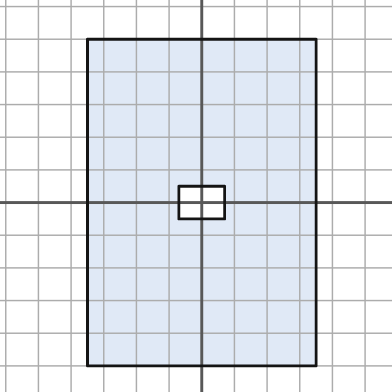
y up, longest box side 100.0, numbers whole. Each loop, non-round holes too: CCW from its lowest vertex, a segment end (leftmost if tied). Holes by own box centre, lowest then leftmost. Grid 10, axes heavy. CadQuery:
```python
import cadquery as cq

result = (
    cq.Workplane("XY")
    .moveTo(-35.0, -50.0)
    .lineTo(35.0, -50.0)
    .lineTo(35.0, 50.0)
    .lineTo(-35.0, 50.0)
    .close()
    .moveTo(-7.0, -5.0)
    .lineTo(7.0, -5.0)
    .lineTo(7.0, 5.0)
    .lineTo(-7.0, 5.0)
    .close()
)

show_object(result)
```